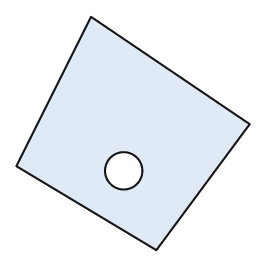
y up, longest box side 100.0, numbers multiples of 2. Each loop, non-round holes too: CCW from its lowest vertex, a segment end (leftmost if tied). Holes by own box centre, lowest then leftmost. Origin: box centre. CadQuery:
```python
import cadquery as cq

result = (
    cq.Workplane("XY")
    .moveTo(10.0, -50.0)
    .lineTo(50.0, 4.0)
    .lineTo(-18.0, 50.0)
    .lineTo(-50.0, -14.0)
    .close()
    .moveTo(-4.0, -16.0)
    .circle(8.0)
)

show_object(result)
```